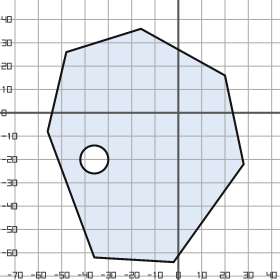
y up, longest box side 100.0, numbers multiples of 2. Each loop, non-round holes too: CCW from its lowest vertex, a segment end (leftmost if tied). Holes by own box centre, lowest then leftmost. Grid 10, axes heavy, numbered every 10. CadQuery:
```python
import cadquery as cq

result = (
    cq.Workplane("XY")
    .moveTo(-2.0, -64.0)
    .lineTo(28.0, -22.0)
    .lineTo(20.0, 16.0)
    .lineTo(-16.0, 36.0)
    .lineTo(-48.0, 26.0)
    .lineTo(-56.0, -8.0)
    .lineTo(-36.0, -62.0)
    .close()
    .moveTo(-36.0, -20.0)
    .circle(6.0)
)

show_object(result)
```